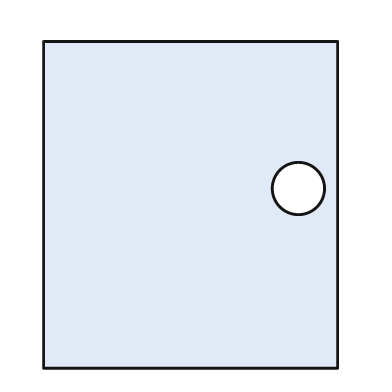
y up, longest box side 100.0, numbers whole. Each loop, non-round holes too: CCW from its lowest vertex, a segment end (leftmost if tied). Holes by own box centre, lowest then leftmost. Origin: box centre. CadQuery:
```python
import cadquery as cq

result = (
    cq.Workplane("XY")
    .moveTo(-45.0, -50.0)
    .lineTo(45.0, -50.0)
    .lineTo(45.0, 50.0)
    .lineTo(-45.0, 50.0)
    .close()
    .moveTo(33.0, 5.0)
    .circle(8.0)
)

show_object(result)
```